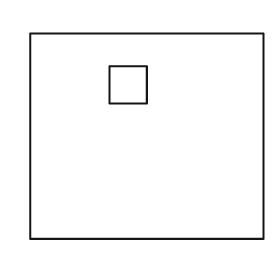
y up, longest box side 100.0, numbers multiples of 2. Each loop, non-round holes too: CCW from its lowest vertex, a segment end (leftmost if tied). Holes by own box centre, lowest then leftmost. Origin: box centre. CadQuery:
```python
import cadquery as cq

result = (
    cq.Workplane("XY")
    .moveTo(-50.0, -44.0)
    .lineTo(50.0, -44.0)
    .lineTo(50.0, 44.0)
    .lineTo(-50.0, 44.0)
    .close()
    .moveTo(-16.0, 14.0)
    .lineTo(0.0, 14.0)
    .lineTo(0.0, 30.0)
    .lineTo(-16.0, 30.0)
    .close()
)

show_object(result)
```